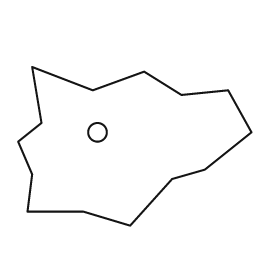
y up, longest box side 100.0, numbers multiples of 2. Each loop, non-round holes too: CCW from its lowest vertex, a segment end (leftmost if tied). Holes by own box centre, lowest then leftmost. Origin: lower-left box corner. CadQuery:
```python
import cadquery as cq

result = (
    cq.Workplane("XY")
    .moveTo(48.0, 0.0)
    .lineTo(66.0, 20.0)
    .lineTo(80.0, 24.0)
    .lineTo(100.0, 40.0)
    .lineTo(90.0, 58.0)
    .lineTo(70.0, 56.0)
    .lineTo(54.0, 66.0)
    .lineTo(32.0, 58.0)
    .lineTo(6.0, 68.0)
    .lineTo(10.0, 44.0)
    .lineTo(0.0, 36.0)
    .lineTo(6.0, 22.0)
    .lineTo(4.0, 6.0)
    .lineTo(28.0, 6.0)
    .close()
    .moveTo(34.0, 40.0)
    .circle(4.0)
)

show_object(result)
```